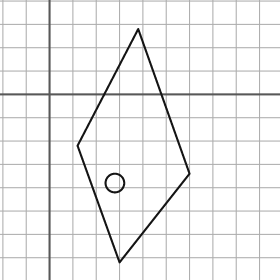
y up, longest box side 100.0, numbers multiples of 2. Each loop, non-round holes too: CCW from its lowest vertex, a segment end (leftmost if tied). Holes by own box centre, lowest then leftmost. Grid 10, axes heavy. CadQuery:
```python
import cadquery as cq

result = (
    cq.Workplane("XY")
    .moveTo(30.0, -72.0)
    .lineTo(60.0, -34.0)
    .lineTo(38.0, 28.0)
    .lineTo(12.0, -22.0)
    .close()
    .moveTo(28.0, -38.0)
    .circle(4.0)
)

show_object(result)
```